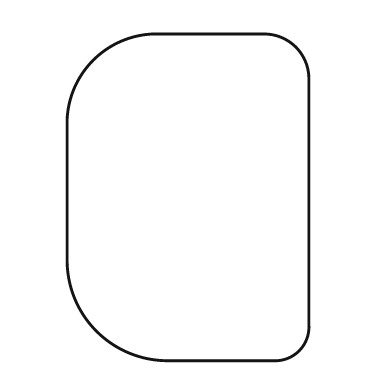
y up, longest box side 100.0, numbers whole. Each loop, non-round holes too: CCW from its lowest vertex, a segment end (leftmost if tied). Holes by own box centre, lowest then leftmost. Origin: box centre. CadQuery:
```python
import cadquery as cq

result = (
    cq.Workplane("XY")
    .moveTo(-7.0, -50.0)
    .lineTo(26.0, -50.0)
    .threePointArc((34.0, -47.0), (37.0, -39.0))
    .lineTo(37.0, 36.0)
    .threePointArc((33.0, 46.0), (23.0, 50.0))
    .lineTo(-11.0, 50.0)
    .threePointArc((-29.0, 42.0), (-37.0, 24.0))
    .lineTo(-37.0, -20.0)
    .threePointArc((-28.0, -41.0), (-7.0, -50.0))
    .close()
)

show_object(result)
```